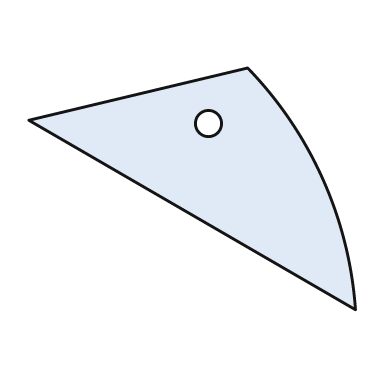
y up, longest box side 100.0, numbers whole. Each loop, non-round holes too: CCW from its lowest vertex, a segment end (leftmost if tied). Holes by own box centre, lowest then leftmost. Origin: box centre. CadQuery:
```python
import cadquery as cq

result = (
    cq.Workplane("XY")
    .moveTo(50.0, -37.0)
    .threePointArc((40.0, 3.0), (17.0, 37.0))
    .lineTo(-50.0, 21.0)
    .close()
    .moveTo(5.0, 20.0)
    .circle(4.0)
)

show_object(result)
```